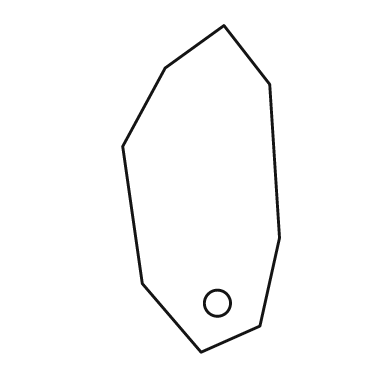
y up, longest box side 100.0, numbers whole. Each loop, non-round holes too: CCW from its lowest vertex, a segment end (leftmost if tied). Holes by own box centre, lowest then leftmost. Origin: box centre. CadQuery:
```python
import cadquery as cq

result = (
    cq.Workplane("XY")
    .moveTo(0.0, -50.0)
    .lineTo(18.0, -42.0)
    .lineTo(24.0, -15.0)
    .lineTo(21.0, 32.0)
    .lineTo(7.0, 50.0)
    .lineTo(-11.0, 37.0)
    .lineTo(-24.0, 13.0)
    .lineTo(-18.0, -29.0)
    .close()
    .moveTo(5.0, -35.0)
    .circle(4.0)
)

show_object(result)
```